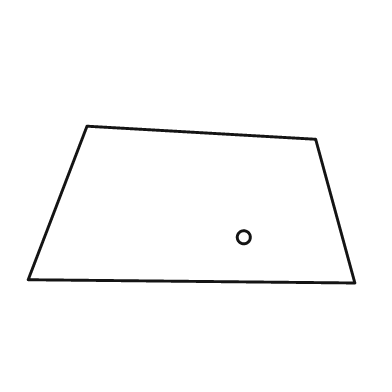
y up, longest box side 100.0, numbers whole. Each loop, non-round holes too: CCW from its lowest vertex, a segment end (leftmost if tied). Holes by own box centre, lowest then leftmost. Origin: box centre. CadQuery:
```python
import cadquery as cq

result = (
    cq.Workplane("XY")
    .moveTo(50.0, -24.0)
    .lineTo(38.0, 20.0)
    .lineTo(-32.0, 24.0)
    .lineTo(-50.0, -23.0)
    .close()
    .moveTo(16.0, -10.0)
    .circle(2.0)
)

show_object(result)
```